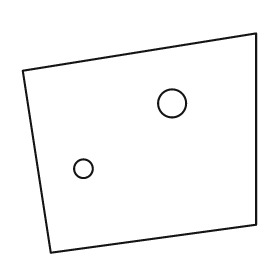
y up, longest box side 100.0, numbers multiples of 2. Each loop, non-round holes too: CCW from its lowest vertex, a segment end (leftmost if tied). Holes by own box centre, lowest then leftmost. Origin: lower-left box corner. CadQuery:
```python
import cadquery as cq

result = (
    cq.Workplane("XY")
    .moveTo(12.0, 0.0)
    .lineTo(100.0, 12.0)
    .lineTo(100.0, 94.0)
    .lineTo(0.0, 78.0)
    .close()
    .moveTo(26.0, 36.0)
    .circle(4.0)
    .moveTo(64.0, 64.0)
    .circle(6.0)
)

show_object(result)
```